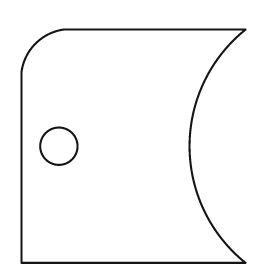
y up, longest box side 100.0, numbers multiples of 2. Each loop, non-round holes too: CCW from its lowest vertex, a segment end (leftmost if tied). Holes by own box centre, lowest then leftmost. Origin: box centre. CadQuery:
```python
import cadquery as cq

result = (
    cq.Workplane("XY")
    .moveTo(-48.0, -50.0)
    .lineTo(48.0, -50.0)
    .threePointArc((24.0, 0.0), (48.0, 50.0))
    .lineTo(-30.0, 50.0)
    .threePointArc((-42.0, 44.0), (-48.0, 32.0))
    .close()
    .moveTo(-32.0, 0.0)
    .circle(8.0)
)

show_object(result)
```